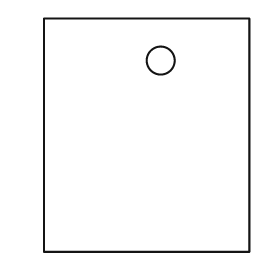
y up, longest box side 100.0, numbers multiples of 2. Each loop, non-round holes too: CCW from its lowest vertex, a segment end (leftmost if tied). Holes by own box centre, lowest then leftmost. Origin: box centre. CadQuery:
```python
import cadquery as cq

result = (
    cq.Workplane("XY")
    .moveTo(-44.0, -50.0)
    .lineTo(44.0, -50.0)
    .lineTo(44.0, 50.0)
    .lineTo(-44.0, 50.0)
    .close()
    .moveTo(6.0, 32.0)
    .circle(6.0)
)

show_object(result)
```